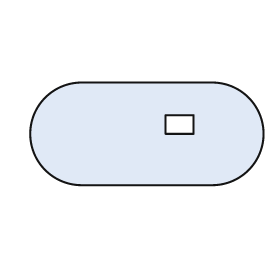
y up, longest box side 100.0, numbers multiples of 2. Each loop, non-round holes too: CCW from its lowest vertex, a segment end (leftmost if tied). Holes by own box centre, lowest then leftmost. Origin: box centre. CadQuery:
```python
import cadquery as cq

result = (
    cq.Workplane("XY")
    .moveTo(-28.0, -22.0)
    .lineTo(28.0, -22.0)
    .threePointArc((50.0, 0.0), (28.0, 22.0))
    .lineTo(-28.0, 22.0)
    .threePointArc((-50.0, 0.0), (-28.0, -22.0))
    .close()
    .moveTo(8.0, 0.0)
    .lineTo(20.0, 0.0)
    .lineTo(20.0, 8.0)
    .lineTo(8.0, 8.0)
    .close()
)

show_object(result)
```